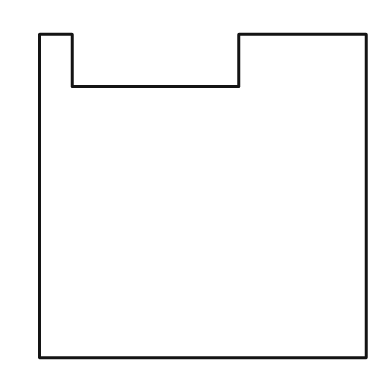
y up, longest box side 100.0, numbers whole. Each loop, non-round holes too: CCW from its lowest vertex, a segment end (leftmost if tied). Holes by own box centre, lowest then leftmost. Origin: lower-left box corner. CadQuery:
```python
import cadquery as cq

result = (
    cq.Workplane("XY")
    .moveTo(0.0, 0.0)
    .lineTo(100.0, 0.0)
    .lineTo(100.0, 99.0)
    .lineTo(61.0, 99.0)
    .lineTo(61.0, 83.0)
    .lineTo(10.0, 83.0)
    .lineTo(10.0, 99.0)
    .lineTo(0.0, 99.0)
    .close()
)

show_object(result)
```